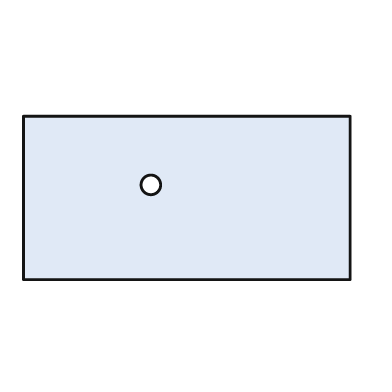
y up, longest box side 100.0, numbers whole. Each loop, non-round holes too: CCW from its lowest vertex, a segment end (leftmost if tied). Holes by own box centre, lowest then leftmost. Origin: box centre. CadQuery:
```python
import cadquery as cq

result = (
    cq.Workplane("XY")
    .moveTo(-50.0, -25.0)
    .lineTo(50.0, -25.0)
    .lineTo(50.0, 25.0)
    .lineTo(-50.0, 25.0)
    .close()
    .moveTo(-11.0, 4.0)
    .circle(3.0)
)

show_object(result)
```